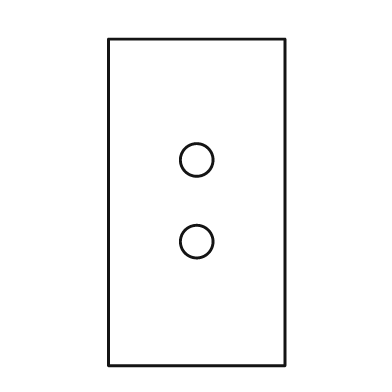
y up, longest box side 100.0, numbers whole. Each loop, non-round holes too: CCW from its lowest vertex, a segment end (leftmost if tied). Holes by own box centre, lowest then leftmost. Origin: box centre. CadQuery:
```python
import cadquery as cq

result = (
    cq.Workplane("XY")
    .moveTo(-27.0, -50.0)
    .lineTo(27.0, -50.0)
    .lineTo(27.0, 50.0)
    .lineTo(-27.0, 50.0)
    .close()
    .moveTo(0.0, -12.0)
    .circle(5.0)
    .moveTo(0.0, 13.0)
    .circle(5.0)
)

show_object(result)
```